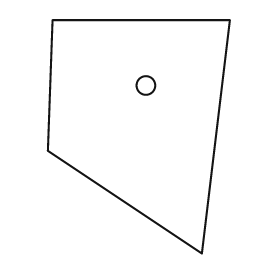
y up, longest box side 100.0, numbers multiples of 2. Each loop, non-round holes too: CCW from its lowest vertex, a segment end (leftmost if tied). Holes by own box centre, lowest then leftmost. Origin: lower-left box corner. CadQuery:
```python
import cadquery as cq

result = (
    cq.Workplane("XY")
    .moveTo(66.0, 0.0)
    .lineTo(78.0, 100.0)
    .lineTo(2.0, 100.0)
    .lineTo(0.0, 44.0)
    .close()
    .moveTo(42.0, 72.0)
    .circle(4.0)
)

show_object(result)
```